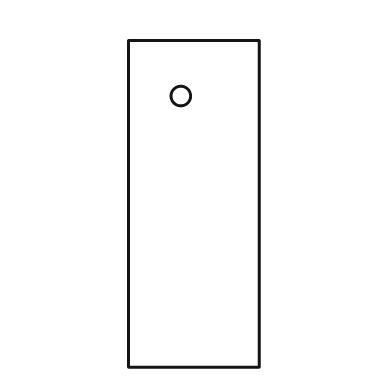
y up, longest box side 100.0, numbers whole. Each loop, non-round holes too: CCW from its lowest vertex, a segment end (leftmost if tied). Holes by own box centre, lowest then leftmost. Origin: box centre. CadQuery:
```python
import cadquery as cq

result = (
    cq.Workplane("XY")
    .moveTo(-20.0, -50.0)
    .lineTo(20.0, -50.0)
    .lineTo(20.0, 50.0)
    .lineTo(-20.0, 50.0)
    .close()
    .moveTo(-4.0, 33.0)
    .circle(3.0)
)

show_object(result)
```